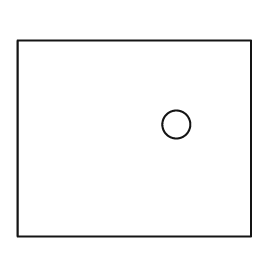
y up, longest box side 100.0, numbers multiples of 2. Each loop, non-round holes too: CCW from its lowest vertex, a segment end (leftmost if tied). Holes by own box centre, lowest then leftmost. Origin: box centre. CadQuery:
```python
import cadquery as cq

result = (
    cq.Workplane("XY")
    .moveTo(-50.0, -42.0)
    .lineTo(50.0, -42.0)
    .lineTo(50.0, 42.0)
    .lineTo(-50.0, 42.0)
    .close()
    .moveTo(18.0, 6.0)
    .circle(6.0)
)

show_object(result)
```